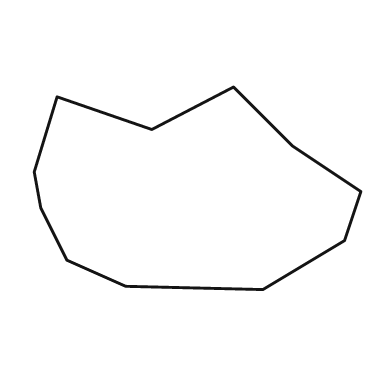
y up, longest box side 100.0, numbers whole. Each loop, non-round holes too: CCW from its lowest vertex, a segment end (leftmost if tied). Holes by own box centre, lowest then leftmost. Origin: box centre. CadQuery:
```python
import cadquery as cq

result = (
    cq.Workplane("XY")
    .moveTo(20.0, -31.0)
    .lineTo(45.0, -16.0)
    .lineTo(50.0, -1.0)
    .lineTo(29.0, 13.0)
    .lineTo(11.0, 31.0)
    .lineTo(-14.0, 18.0)
    .lineTo(-43.0, 28.0)
    .lineTo(-50.0, 5.0)
    .lineTo(-48.0, -6.0)
    .lineTo(-40.0, -22.0)
    .lineTo(-22.0, -30.0)
    .close()
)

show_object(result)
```